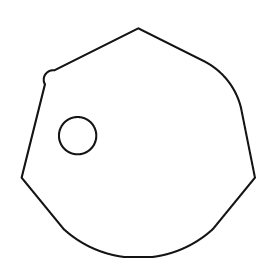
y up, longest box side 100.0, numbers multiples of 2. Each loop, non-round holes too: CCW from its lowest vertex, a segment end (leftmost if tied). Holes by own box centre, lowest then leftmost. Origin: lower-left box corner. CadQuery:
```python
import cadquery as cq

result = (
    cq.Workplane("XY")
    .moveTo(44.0, 0.0)
    .lineTo(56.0, 0.0)
    .threePointArc((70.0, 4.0), (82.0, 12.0))
    .lineTo(100.0, 34.0)
    .lineTo(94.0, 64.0)
    .threePointArc((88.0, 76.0), (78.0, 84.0))
    .lineTo(50.0, 98.0)
    .lineTo(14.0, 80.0)
    .threePointArc((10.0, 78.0), (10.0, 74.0))
    .lineTo(0.0, 34.0)
    .lineTo(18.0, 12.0)
    .threePointArc((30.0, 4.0), (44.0, 0.0))
    .close()
    .moveTo(24.0, 52.0)
    .circle(8.0)
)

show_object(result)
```